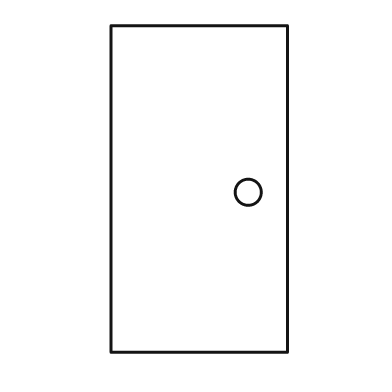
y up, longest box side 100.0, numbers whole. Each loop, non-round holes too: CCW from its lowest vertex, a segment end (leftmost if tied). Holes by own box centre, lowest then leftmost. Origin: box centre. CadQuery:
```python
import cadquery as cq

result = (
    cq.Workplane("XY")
    .moveTo(-27.0, -50.0)
    .lineTo(27.0, -50.0)
    .lineTo(27.0, 50.0)
    .lineTo(-27.0, 50.0)
    .close()
    .moveTo(15.0, -1.0)
    .circle(4.0)
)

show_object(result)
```